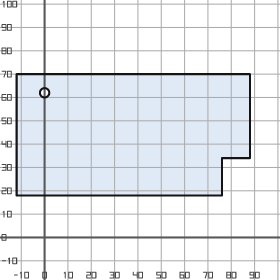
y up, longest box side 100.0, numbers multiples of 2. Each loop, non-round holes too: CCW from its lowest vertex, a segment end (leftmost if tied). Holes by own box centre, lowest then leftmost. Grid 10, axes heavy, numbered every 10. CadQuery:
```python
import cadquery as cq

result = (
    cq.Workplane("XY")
    .moveTo(-12.0, 18.0)
    .lineTo(76.0, 18.0)
    .lineTo(76.0, 34.0)
    .lineTo(88.0, 34.0)
    .lineTo(88.0, 70.0)
    .lineTo(-12.0, 70.0)
    .close()
    .moveTo(0.0, 62.0)
    .circle(2.0)
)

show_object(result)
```